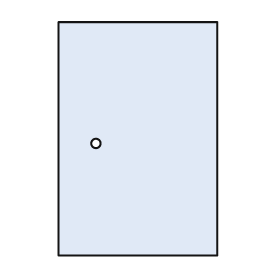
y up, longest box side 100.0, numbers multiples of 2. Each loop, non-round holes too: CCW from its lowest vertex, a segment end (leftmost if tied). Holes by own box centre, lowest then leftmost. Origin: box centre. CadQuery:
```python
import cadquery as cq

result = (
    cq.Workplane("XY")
    .moveTo(-34.0, -50.0)
    .lineTo(34.0, -50.0)
    .lineTo(34.0, 50.0)
    .lineTo(-34.0, 50.0)
    .close()
    .moveTo(-18.0, -2.0)
    .circle(2.0)
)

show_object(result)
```